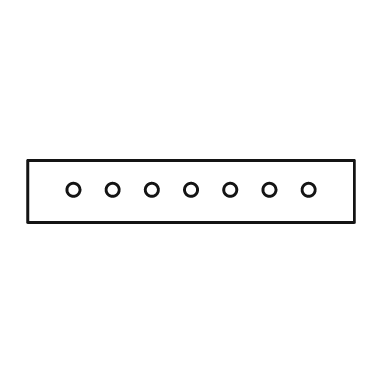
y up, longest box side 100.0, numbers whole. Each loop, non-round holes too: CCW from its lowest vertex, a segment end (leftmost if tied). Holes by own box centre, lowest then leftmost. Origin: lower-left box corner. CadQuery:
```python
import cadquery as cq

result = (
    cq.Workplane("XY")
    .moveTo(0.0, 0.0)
    .lineTo(100.0, 0.0)
    .lineTo(100.0, 19.0)
    .lineTo(0.0, 19.0)
    .close()
    .moveTo(14.0, 10.0)
    .circle(2.0)
    .moveTo(26.0, 10.0)
    .circle(2.0)
    .moveTo(38.0, 10.0)
    .circle(2.0)
    .moveTo(50.0, 10.0)
    .circle(2.0)
    .moveTo(62.0, 10.0)
    .circle(2.0)
    .moveTo(74.0, 10.0)
    .circle(2.0)
    .moveTo(86.0, 10.0)
    .circle(2.0)
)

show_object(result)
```